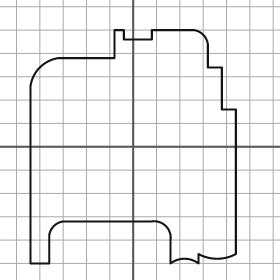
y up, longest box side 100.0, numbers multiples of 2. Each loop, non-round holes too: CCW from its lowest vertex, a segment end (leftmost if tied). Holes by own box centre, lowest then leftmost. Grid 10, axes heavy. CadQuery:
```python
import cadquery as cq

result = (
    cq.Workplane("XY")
    .moveTo(-44.0, -50.0)
    .lineTo(-36.0, -50.0)
    .lineTo(-36.0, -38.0)
    .threePointArc((-34.0, -34.0), (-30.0, -32.0))
    .lineTo(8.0, -32.0)
    .threePointArc((14.0, -34.0), (16.0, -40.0))
    .lineTo(16.0, -50.0)
    .threePointArc((22.0, -48.0), (28.0, -50.0))
    .lineTo(28.0, -46.0)
    .threePointArc((36.0, -48.0), (44.0, -46.0))
    .lineTo(44.0, 16.0)
    .lineTo(38.0, 16.0)
    .lineTo(38.0, 34.0)
    .lineTo(32.0, 34.0)
    .lineTo(32.0, 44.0)
    .threePointArc((30.0, 48.0), (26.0, 50.0))
    .lineTo(8.0, 50.0)
    .lineTo(8.0, 46.0)
    .lineTo(-4.0, 46.0)
    .lineTo(-4.0, 50.0)
    .lineTo(-8.0, 50.0)
    .lineTo(-8.0, 38.0)
    .lineTo(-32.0, 38.0)
    .threePointArc((-40.0, 34.0), (-44.0, 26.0))
    .close()
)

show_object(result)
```